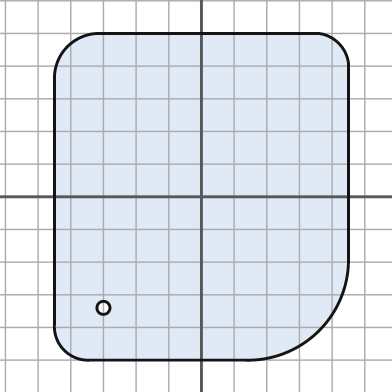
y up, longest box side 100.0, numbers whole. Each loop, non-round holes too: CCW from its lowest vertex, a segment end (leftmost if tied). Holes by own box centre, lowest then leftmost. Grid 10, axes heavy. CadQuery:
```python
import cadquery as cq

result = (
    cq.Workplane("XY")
    .moveTo(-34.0, -50.0)
    .lineTo(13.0, -50.0)
    .threePointArc((36.0, -41.0), (45.0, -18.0))
    .lineTo(45.0, 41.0)
    .threePointArc((42.0, 47.0), (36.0, 50.0))
    .lineTo(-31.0, 50.0)
    .threePointArc((-41.0, 46.0), (-45.0, 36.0))
    .lineTo(-45.0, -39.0)
    .threePointArc((-42.0, -47.0), (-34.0, -50.0))
    .close()
    .moveTo(-30.0, -34.0)
    .circle(2.0)
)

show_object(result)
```